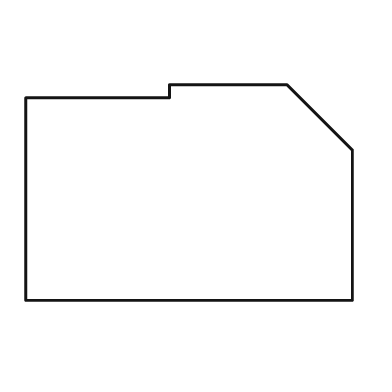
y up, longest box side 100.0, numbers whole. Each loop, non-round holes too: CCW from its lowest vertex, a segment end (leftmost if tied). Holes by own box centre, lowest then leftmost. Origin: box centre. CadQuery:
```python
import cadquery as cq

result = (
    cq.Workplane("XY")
    .moveTo(-50.0, -33.0)
    .lineTo(50.0, -33.0)
    .lineTo(50.0, 13.0)
    .lineTo(30.0, 33.0)
    .lineTo(-6.0, 33.0)
    .lineTo(-6.0, 29.0)
    .lineTo(-50.0, 29.0)
    .close()
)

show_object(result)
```